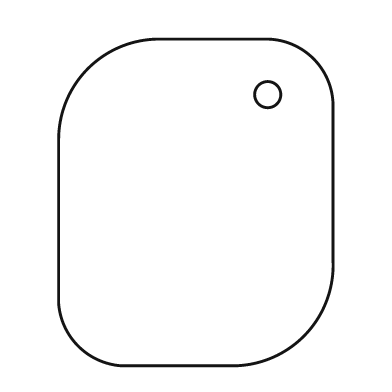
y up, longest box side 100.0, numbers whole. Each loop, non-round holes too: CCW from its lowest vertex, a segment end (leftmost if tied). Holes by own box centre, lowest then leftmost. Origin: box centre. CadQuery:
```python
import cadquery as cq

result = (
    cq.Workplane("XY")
    .moveTo(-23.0, -50.0)
    .lineTo(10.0, -50.0)
    .threePointArc((33.0, -41.0), (42.0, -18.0))
    .lineTo(42.0, 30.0)
    .threePointArc((36.0, 44.0), (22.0, 50.0))
    .lineTo(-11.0, 50.0)
    .threePointArc((-33.0, 41.0), (-42.0, 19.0))
    .lineTo(-42.0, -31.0)
    .threePointArc((-36.0, -44.0), (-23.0, -50.0))
    .close()
    .moveTo(22.0, 33.0)
    .circle(4.0)
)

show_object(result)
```